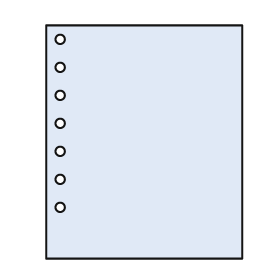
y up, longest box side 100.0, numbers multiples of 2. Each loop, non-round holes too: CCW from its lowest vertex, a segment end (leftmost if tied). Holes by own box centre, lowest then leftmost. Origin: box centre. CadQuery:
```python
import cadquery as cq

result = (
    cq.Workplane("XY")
    .moveTo(-42.0, -50.0)
    .lineTo(42.0, -50.0)
    .lineTo(42.0, 50.0)
    .lineTo(-42.0, 50.0)
    .close()
    .moveTo(-36.0, -28.0)
    .circle(2.0)
    .moveTo(-36.0, -16.0)
    .circle(2.0)
    .moveTo(-36.0, -4.0)
    .circle(2.0)
    .moveTo(-36.0, 8.0)
    .circle(2.0)
    .moveTo(-36.0, 20.0)
    .circle(2.0)
    .moveTo(-36.0, 32.0)
    .circle(2.0)
    .moveTo(-36.0, 44.0)
    .circle(2.0)
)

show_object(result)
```